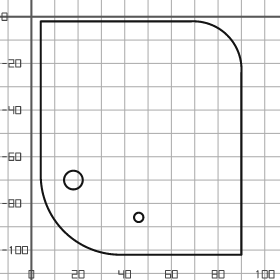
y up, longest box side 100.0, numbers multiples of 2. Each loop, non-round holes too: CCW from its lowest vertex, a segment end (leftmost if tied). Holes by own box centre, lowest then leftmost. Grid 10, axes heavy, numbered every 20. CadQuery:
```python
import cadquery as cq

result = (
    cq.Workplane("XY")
    .moveTo(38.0, -102.0)
    .lineTo(90.0, -102.0)
    .lineTo(90.0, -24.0)
    .threePointArc((84.0, -8.0), (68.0, -2.0))
    .lineTo(4.0, -2.0)
    .lineTo(4.0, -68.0)
    .threePointArc((14.0, -92.0), (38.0, -102.0))
    .close()
    .moveTo(46.0, -86.0)
    .circle(2.0)
    .moveTo(18.0, -70.0)
    .circle(4.0)
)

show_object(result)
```